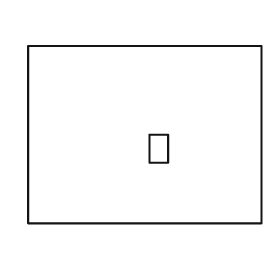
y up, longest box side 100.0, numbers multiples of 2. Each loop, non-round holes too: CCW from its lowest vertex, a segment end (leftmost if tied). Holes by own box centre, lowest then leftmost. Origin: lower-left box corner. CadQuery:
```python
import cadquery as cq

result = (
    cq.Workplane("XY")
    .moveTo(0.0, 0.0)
    .lineTo(100.0, 0.0)
    .lineTo(100.0, 76.0)
    .lineTo(0.0, 76.0)
    .close()
    .moveTo(52.0, 26.0)
    .lineTo(60.0, 26.0)
    .lineTo(60.0, 38.0)
    .lineTo(52.0, 38.0)
    .close()
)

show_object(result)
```